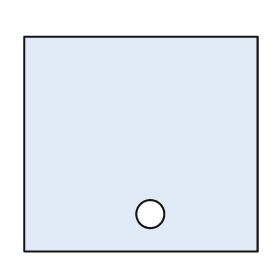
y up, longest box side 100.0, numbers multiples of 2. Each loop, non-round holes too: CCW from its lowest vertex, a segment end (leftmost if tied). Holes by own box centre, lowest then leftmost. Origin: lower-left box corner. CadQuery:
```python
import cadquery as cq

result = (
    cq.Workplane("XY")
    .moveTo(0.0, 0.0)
    .lineTo(100.0, 0.0)
    .lineTo(100.0, 92.0)
    .lineTo(0.0, 92.0)
    .close()
    .moveTo(54.0, 16.0)
    .circle(6.0)
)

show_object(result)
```